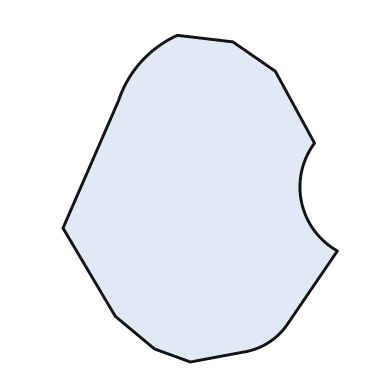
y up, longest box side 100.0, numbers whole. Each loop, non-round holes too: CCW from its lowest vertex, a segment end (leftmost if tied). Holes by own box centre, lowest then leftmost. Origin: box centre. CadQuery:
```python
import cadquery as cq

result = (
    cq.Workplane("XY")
    .moveTo(-3.0, -50.0)
    .lineTo(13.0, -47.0)
    .threePointArc((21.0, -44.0), (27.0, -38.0))
    .lineTo(42.0, -16.0)
    .threePointArc((31.0, -1.0), (35.0, 17.0))
    .lineTo(23.0, 39.0)
    .lineTo(10.0, 48.0)
    .lineTo(-7.0, 50.0)
    .threePointArc((-18.0, 42.0), (-25.0, 30.0))
    .lineTo(-42.0, -9.0)
    .lineTo(-26.0, -36.0)
    .lineTo(-14.0, -46.0)
    .close()
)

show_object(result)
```